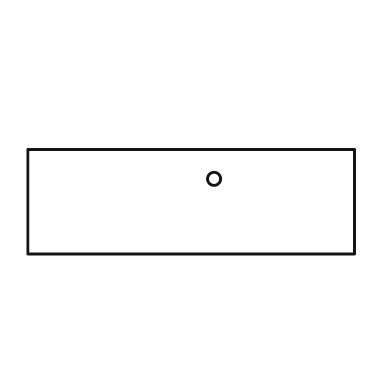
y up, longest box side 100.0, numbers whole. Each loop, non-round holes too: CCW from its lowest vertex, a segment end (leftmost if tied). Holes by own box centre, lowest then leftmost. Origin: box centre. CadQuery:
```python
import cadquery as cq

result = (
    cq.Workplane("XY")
    .moveTo(-50.0, -16.0)
    .lineTo(50.0, -16.0)
    .lineTo(50.0, 16.0)
    .lineTo(-50.0, 16.0)
    .close()
    .moveTo(7.0, 7.0)
    .circle(2.0)
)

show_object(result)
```